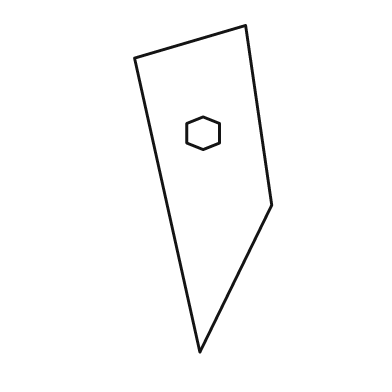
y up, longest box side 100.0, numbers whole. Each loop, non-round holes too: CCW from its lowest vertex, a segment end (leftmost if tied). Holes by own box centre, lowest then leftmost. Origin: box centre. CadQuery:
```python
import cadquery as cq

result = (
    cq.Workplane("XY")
    .moveTo(-1.0, -50.0)
    .lineTo(21.0, -5.0)
    .lineTo(13.0, 50.0)
    .lineTo(-21.0, 40.0)
    .close()
    .moveTo(0.0, 12.0)
    .lineTo(5.0, 14.0)
    .lineTo(5.0, 20.0)
    .lineTo(0.0, 22.0)
    .lineTo(-5.0, 20.0)
    .lineTo(-5.0, 14.0)
    .close()
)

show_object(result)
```